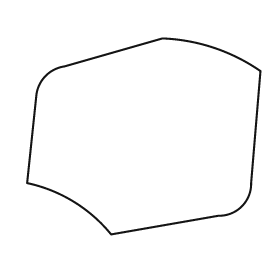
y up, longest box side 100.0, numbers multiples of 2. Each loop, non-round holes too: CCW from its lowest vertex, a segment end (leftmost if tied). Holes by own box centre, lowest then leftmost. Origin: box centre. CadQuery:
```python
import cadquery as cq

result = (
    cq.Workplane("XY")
    .moveTo(-14.0, -42.0)
    .lineTo(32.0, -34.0)
    .threePointArc((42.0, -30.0), (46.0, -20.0))
    .lineTo(50.0, 28.0)
    .threePointArc((30.0, 38.0), (8.0, 42.0))
    .lineTo(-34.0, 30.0)
    .threePointArc((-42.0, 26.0), (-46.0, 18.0))
    .lineTo(-50.0, -20.0)
    .threePointArc((-30.0, -28.0), (-14.0, -42.0))
    .close()
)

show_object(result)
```